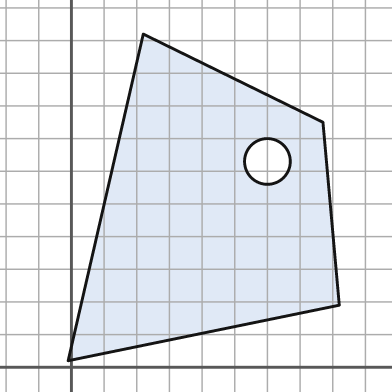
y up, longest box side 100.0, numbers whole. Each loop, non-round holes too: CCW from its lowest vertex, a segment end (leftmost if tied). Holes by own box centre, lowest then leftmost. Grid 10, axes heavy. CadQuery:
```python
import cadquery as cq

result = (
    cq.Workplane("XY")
    .moveTo(-1.0, 2.0)
    .lineTo(82.0, 19.0)
    .lineTo(77.0, 75.0)
    .lineTo(22.0, 102.0)
    .close()
    .moveTo(60.0, 63.0)
    .circle(7.0)
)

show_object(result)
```